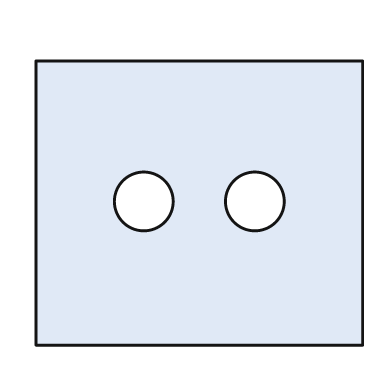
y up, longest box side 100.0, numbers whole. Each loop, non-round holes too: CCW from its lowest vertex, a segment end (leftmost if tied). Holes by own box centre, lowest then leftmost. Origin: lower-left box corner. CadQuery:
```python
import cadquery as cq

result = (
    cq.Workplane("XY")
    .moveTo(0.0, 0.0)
    .lineTo(100.0, 0.0)
    .lineTo(100.0, 87.0)
    .lineTo(0.0, 87.0)
    .close()
    .moveTo(33.0, 44.0)
    .circle(9.0)
    .moveTo(67.0, 44.0)
    .circle(9.0)
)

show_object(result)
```